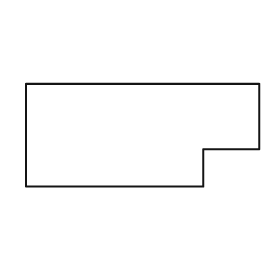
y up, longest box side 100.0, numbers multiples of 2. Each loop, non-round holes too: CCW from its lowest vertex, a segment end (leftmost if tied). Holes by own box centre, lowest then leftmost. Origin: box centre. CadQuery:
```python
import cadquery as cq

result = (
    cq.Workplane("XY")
    .moveTo(-50.0, -22.0)
    .lineTo(26.0, -22.0)
    .lineTo(26.0, -6.0)
    .lineTo(50.0, -6.0)
    .lineTo(50.0, 22.0)
    .lineTo(-50.0, 22.0)
    .close()
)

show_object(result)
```